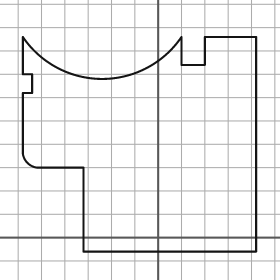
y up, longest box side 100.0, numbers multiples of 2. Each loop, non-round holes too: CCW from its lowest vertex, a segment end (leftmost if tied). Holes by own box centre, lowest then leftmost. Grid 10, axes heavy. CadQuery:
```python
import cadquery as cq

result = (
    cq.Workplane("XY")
    .moveTo(-32.0, -6.0)
    .lineTo(42.0, -6.0)
    .lineTo(42.0, 86.0)
    .lineTo(20.0, 86.0)
    .lineTo(20.0, 74.0)
    .lineTo(10.0, 74.0)
    .lineTo(10.0, 86.0)
    .threePointArc((-24.0, 68.0), (-58.0, 86.0))
    .lineTo(-58.0, 70.0)
    .lineTo(-54.0, 70.0)
    .lineTo(-54.0, 62.0)
    .lineTo(-58.0, 62.0)
    .lineTo(-58.0, 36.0)
    .threePointArc((-56.0, 32.0), (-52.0, 30.0))
    .lineTo(-32.0, 30.0)
    .close()
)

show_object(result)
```